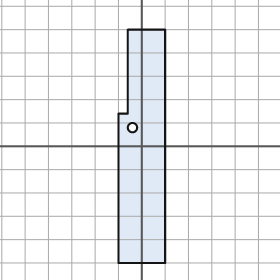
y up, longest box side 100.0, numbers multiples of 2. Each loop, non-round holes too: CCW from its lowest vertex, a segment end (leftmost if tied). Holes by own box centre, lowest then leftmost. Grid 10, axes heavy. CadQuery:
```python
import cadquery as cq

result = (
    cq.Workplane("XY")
    .moveTo(-10.0, -50.0)
    .lineTo(10.0, -50.0)
    .lineTo(10.0, 50.0)
    .lineTo(-6.0, 50.0)
    .lineTo(-6.0, 14.0)
    .lineTo(-10.0, 14.0)
    .close()
    .moveTo(-4.0, 8.0)
    .circle(2.0)
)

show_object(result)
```